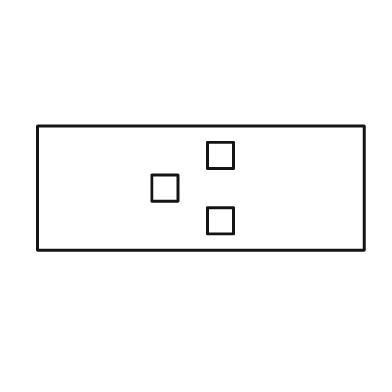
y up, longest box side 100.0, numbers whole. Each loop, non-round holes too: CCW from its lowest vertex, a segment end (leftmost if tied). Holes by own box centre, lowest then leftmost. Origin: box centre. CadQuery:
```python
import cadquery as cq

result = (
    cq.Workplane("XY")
    .moveTo(-50.0, -19.0)
    .lineTo(50.0, -19.0)
    .lineTo(50.0, 19.0)
    .lineTo(-50.0, 19.0)
    .close()
    .moveTo(2.0, -14.0)
    .lineTo(10.0, -14.0)
    .lineTo(10.0, -6.0)
    .lineTo(2.0, -6.0)
    .close()
    .moveTo(-15.0, -4.0)
    .lineTo(-7.0, -4.0)
    .lineTo(-7.0, 4.0)
    .lineTo(-15.0, 4.0)
    .close()
    .moveTo(2.0, 6.0)
    .lineTo(10.0, 6.0)
    .lineTo(10.0, 14.0)
    .lineTo(2.0, 14.0)
    .close()
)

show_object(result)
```